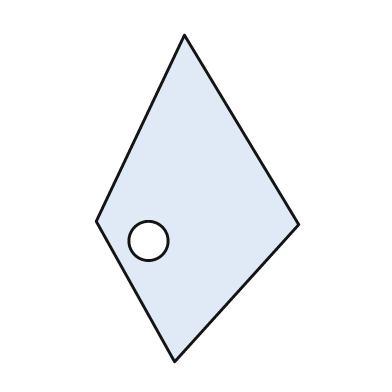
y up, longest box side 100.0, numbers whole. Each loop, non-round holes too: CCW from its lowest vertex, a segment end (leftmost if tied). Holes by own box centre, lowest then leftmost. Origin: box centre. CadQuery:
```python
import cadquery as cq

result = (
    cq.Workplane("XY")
    .moveTo(-7.0, -50.0)
    .lineTo(31.0, -8.0)
    .lineTo(-4.0, 50.0)
    .lineTo(-31.0, -7.0)
    .close()
    .moveTo(-15.0, -13.0)
    .circle(6.0)
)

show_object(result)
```